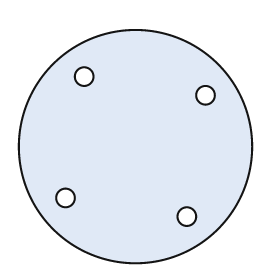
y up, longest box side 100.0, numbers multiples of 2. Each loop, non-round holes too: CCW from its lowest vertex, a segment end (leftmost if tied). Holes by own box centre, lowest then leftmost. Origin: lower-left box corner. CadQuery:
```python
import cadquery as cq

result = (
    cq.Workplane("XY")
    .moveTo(50.0, 50.0)
    .circle(50.0)
    .moveTo(72.0, 20.0)
    .circle(4.0)
    .moveTo(20.0, 28.0)
    .circle(4.0)
    .moveTo(80.0, 72.0)
    .circle(4.0)
    .moveTo(28.0, 80.0)
    .circle(4.0)
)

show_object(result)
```